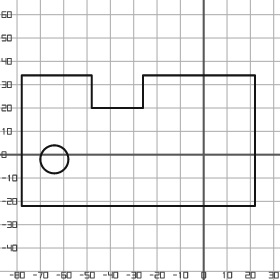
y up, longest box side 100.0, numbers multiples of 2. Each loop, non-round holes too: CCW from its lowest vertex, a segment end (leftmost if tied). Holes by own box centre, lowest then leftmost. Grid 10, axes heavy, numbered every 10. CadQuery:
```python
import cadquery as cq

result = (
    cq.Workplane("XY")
    .moveTo(-78.0, -22.0)
    .lineTo(22.0, -22.0)
    .lineTo(22.0, 34.0)
    .lineTo(-26.0, 34.0)
    .lineTo(-26.0, 20.0)
    .lineTo(-48.0, 20.0)
    .lineTo(-48.0, 34.0)
    .lineTo(-78.0, 34.0)
    .close()
    .moveTo(-64.0, -2.0)
    .circle(6.0)
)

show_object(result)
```